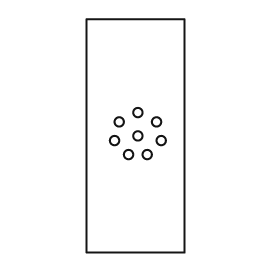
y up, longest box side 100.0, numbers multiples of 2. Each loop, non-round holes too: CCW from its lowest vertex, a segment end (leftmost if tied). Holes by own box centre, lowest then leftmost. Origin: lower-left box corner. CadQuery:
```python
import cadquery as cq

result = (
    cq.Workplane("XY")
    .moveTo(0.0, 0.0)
    .lineTo(42.0, 0.0)
    .lineTo(42.0, 100.0)
    .lineTo(0.0, 100.0)
    .close()
    .moveTo(18.0, 42.0)
    .circle(2.0)
    .moveTo(26.0, 42.0)
    .circle(2.0)
    .moveTo(12.0, 48.0)
    .circle(2.0)
    .moveTo(32.0, 48.0)
    .circle(2.0)
    .moveTo(22.0, 50.0)
    .circle(2.0)
    .moveTo(14.0, 56.0)
    .circle(2.0)
    .moveTo(30.0, 56.0)
    .circle(2.0)
    .moveTo(22.0, 60.0)
    .circle(2.0)
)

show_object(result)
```